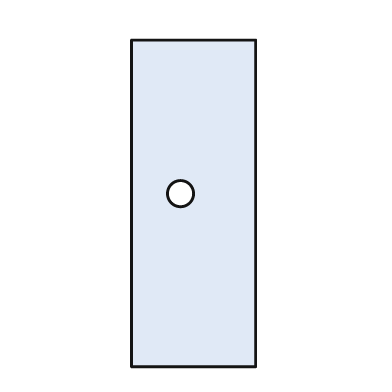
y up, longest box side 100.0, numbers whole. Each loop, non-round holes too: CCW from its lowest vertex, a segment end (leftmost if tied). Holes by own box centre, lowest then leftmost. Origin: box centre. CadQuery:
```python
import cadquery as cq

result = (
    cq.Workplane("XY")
    .moveTo(-19.0, -50.0)
    .lineTo(19.0, -50.0)
    .lineTo(19.0, 50.0)
    .lineTo(-19.0, 50.0)
    .close()
    .moveTo(-4.0, 3.0)
    .circle(4.0)
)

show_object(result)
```